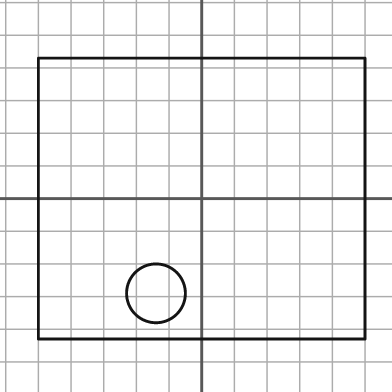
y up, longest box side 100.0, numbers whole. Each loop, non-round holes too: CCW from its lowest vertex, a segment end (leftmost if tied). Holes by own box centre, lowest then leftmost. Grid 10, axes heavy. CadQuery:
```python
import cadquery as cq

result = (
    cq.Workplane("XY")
    .moveTo(-50.0, -43.0)
    .lineTo(50.0, -43.0)
    .lineTo(50.0, 43.0)
    .lineTo(-50.0, 43.0)
    .close()
    .moveTo(-14.0, -29.0)
    .circle(9.0)
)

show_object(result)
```